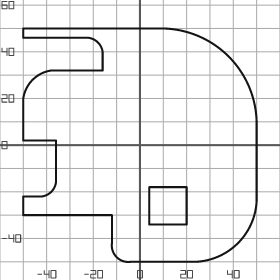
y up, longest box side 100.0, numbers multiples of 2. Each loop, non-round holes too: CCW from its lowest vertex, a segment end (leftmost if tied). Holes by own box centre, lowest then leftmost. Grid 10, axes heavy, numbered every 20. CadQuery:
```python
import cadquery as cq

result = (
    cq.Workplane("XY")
    .moveTo(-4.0, -50.0)
    .lineTo(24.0, -50.0)
    .threePointArc((42.0, -42.0), (50.0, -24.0))
    .lineTo(50.0, 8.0)
    .threePointArc((38.0, 38.0), (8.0, 50.0))
    .lineTo(-50.0, 50.0)
    .lineTo(-50.0, 46.0)
    .lineTo(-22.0, 46.0)
    .threePointArc((-18.0, 44.0), (-16.0, 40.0))
    .lineTo(-16.0, 32.0)
    .lineTo(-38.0, 32.0)
    .threePointArc((-46.0, 28.0), (-50.0, 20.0))
    .lineTo(-50.0, 2.0)
    .lineTo(-36.0, 2.0)
    .lineTo(-36.0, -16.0)
    .threePointArc((-38.0, -20.0), (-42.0, -22.0))
    .lineTo(-50.0, -22.0)
    .lineTo(-50.0, -30.0)
    .lineTo(-12.0, -30.0)
    .lineTo(-12.0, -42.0)
    .threePointArc((-10.0, -48.0), (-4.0, -50.0))
    .close()
    .moveTo(4.0, -34.0)
    .lineTo(20.0, -34.0)
    .lineTo(20.0, -18.0)
    .lineTo(4.0, -18.0)
    .close()
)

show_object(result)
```